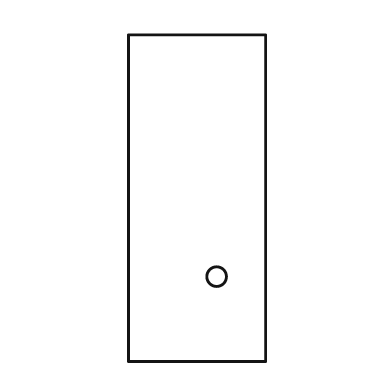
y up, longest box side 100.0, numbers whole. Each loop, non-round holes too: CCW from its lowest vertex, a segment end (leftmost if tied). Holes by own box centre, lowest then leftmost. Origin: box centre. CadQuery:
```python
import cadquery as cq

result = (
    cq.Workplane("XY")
    .moveTo(-21.0, -50.0)
    .lineTo(21.0, -50.0)
    .lineTo(21.0, 50.0)
    .lineTo(-21.0, 50.0)
    .close()
    .moveTo(6.0, -24.0)
    .circle(3.0)
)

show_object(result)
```